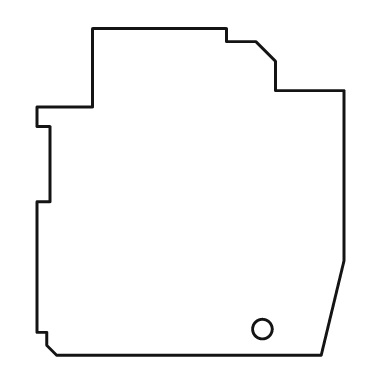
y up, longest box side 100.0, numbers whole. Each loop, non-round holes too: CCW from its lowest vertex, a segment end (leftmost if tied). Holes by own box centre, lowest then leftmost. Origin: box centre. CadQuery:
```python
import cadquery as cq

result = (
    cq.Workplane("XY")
    .moveTo(-41.0, -50.0)
    .lineTo(40.0, -50.0)
    .lineTo(47.0, -21.0)
    .lineTo(47.0, 31.0)
    .lineTo(26.0, 31.0)
    .lineTo(26.0, 40.0)
    .lineTo(20.0, 46.0)
    .lineTo(11.0, 46.0)
    .lineTo(11.0, 50.0)
    .lineTo(-30.0, 50.0)
    .lineTo(-30.0, 26.0)
    .lineTo(-47.0, 26.0)
    .lineTo(-47.0, 20.0)
    .lineTo(-43.0, 20.0)
    .lineTo(-43.0, -3.0)
    .lineTo(-47.0, -3.0)
    .lineTo(-47.0, -43.0)
    .lineTo(-44.0, -43.0)
    .lineTo(-44.0, -47.0)
    .close()
    .moveTo(22.0, -42.0)
    .circle(3.0)
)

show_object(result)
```